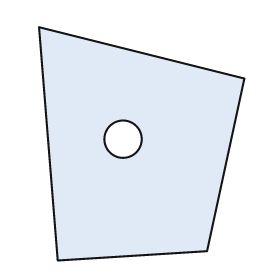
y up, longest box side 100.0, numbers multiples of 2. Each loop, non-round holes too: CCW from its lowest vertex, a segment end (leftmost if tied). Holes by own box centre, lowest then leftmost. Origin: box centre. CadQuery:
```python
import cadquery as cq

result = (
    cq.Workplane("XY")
    .moveTo(-36.0, -50.0)
    .lineTo(28.0, -46.0)
    .lineTo(44.0, 28.0)
    .lineTo(-44.0, 50.0)
    .close()
    .moveTo(-8.0, 2.0)
    .circle(8.0)
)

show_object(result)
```